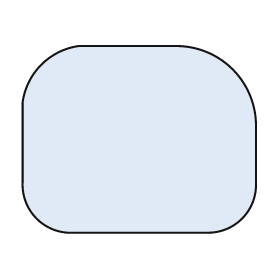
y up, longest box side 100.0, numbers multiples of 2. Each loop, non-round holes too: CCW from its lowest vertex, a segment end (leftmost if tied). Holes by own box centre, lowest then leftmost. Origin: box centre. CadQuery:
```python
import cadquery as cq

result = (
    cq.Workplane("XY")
    .moveTo(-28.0, -40.0)
    .lineTo(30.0, -40.0)
    .threePointArc((44.0, -34.0), (50.0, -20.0))
    .lineTo(50.0, 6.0)
    .threePointArc((40.0, 30.0), (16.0, 40.0))
    .lineTo(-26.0, 40.0)
    .threePointArc((-42.0, 32.0), (-50.0, 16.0))
    .lineTo(-50.0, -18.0)
    .threePointArc((-44.0, -34.0), (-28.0, -40.0))
    .close()
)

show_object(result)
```